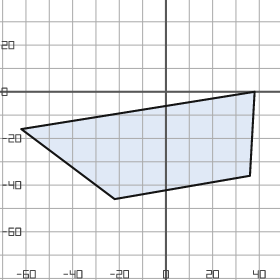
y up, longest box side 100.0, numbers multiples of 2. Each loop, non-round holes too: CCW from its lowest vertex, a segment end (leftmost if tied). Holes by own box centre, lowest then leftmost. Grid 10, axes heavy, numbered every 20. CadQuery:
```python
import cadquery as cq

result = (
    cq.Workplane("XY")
    .moveTo(-22.0, -46.0)
    .lineTo(36.0, -36.0)
    .lineTo(38.0, 0.0)
    .lineTo(-62.0, -16.0)
    .close()
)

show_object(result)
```